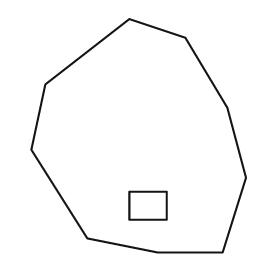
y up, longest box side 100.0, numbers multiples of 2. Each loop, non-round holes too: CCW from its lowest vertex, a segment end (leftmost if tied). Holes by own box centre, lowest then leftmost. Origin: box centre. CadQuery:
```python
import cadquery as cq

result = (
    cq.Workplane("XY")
    .moveTo(8.0, -50.0)
    .lineTo(36.0, -50.0)
    .lineTo(46.0, -18.0)
    .lineTo(38.0, 12.0)
    .lineTo(20.0, 42.0)
    .lineTo(-4.0, 50.0)
    .lineTo(-40.0, 22.0)
    .lineTo(-46.0, -6.0)
    .lineTo(-22.0, -44.0)
    .close()
    .moveTo(-4.0, -36.0)
    .lineTo(12.0, -36.0)
    .lineTo(12.0, -24.0)
    .lineTo(-4.0, -24.0)
    .close()
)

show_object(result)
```